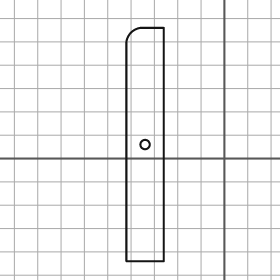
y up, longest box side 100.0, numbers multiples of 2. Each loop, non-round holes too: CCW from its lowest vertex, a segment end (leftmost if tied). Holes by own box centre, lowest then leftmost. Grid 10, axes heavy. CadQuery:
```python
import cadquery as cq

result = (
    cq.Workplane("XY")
    .moveTo(-42.0, -44.0)
    .lineTo(-26.0, -44.0)
    .lineTo(-26.0, 56.0)
    .lineTo(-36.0, 56.0)
    .threePointArc((-40.0, 54.0), (-42.0, 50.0))
    .close()
    .moveTo(-34.0, 6.0)
    .circle(2.0)
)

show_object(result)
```